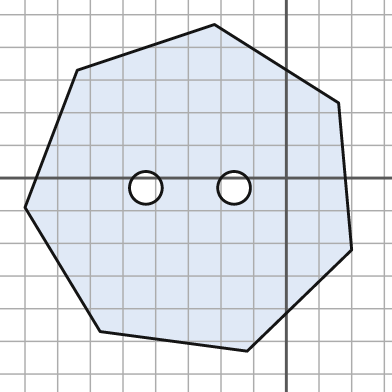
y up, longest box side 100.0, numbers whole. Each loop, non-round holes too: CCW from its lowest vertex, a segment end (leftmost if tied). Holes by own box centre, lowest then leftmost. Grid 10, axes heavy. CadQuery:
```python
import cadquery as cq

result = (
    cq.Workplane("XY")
    .moveTo(-12.0, -53.0)
    .lineTo(20.0, -22.0)
    .lineTo(16.0, 23.0)
    .lineTo(-22.0, 47.0)
    .lineTo(-64.0, 33.0)
    .lineTo(-80.0, -9.0)
    .lineTo(-57.0, -47.0)
    .close()
    .moveTo(-43.0, -3.0)
    .circle(5.0)
    .moveTo(-16.0, -3.0)
    .circle(5.0)
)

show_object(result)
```